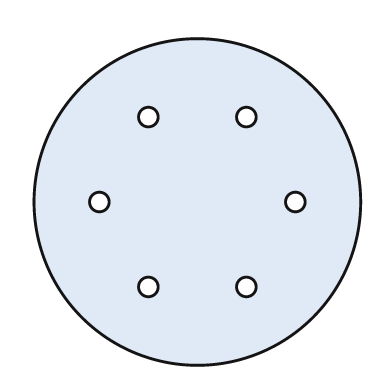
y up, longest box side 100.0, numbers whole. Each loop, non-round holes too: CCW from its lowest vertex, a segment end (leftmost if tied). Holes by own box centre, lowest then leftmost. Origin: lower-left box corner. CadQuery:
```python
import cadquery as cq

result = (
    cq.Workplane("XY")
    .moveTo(50.0, 50.0)
    .circle(50.0)
    .moveTo(35.0, 24.0)
    .circle(3.0)
    .moveTo(65.0, 24.0)
    .circle(3.0)
    .moveTo(20.0, 50.0)
    .circle(3.0)
    .moveTo(80.0, 50.0)
    .circle(3.0)
    .moveTo(35.0, 76.0)
    .circle(3.0)
    .moveTo(65.0, 76.0)
    .circle(3.0)
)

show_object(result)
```